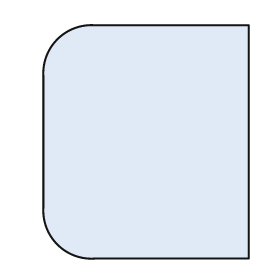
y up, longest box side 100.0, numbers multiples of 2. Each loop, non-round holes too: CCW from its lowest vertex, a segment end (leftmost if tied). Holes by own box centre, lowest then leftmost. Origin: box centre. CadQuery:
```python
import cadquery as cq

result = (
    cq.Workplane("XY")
    .moveTo(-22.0, -50.0)
    .lineTo(44.0, -50.0)
    .lineTo(44.0, 50.0)
    .lineTo(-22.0, 50.0)
    .threePointArc((-38.0, 44.0), (-44.0, 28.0))
    .lineTo(-44.0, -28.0)
    .threePointArc((-38.0, -44.0), (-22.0, -50.0))
    .close()
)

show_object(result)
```